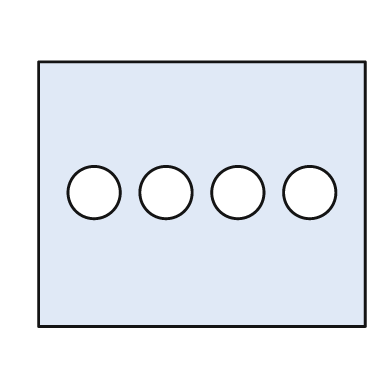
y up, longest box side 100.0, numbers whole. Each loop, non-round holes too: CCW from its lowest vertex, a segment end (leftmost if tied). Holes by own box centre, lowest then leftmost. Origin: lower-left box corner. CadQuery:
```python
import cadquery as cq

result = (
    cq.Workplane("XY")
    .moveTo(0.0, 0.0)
    .lineTo(100.0, 0.0)
    .lineTo(100.0, 81.0)
    .lineTo(0.0, 81.0)
    .close()
    .moveTo(17.0, 41.0)
    .circle(8.0)
    .moveTo(39.0, 41.0)
    .circle(8.0)
    .moveTo(61.0, 41.0)
    .circle(8.0)
    .moveTo(83.0, 41.0)
    .circle(8.0)
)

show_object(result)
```